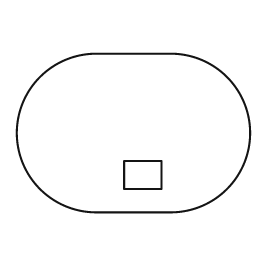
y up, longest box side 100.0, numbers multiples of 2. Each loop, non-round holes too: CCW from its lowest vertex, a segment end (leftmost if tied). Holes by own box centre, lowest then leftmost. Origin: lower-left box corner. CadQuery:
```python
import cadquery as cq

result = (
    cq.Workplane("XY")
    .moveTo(34.0, 0.0)
    .lineTo(66.0, 0.0)
    .threePointArc((100.0, 34.0), (66.0, 68.0))
    .lineTo(34.0, 68.0)
    .threePointArc((0.0, 34.0), (34.0, 0.0))
    .close()
    .moveTo(46.0, 10.0)
    .lineTo(62.0, 10.0)
    .lineTo(62.0, 22.0)
    .lineTo(46.0, 22.0)
    .close()
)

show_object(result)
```